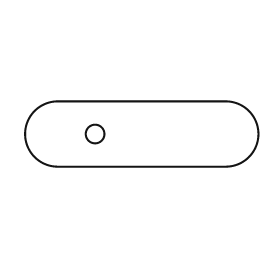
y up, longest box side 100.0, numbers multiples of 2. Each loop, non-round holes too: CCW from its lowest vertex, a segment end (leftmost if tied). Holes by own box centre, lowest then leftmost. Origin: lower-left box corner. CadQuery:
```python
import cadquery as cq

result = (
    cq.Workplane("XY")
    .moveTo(14.0, 0.0)
    .lineTo(86.0, 0.0)
    .threePointArc((100.0, 14.0), (86.0, 28.0))
    .lineTo(14.0, 28.0)
    .threePointArc((0.0, 14.0), (14.0, 0.0))
    .close()
    .moveTo(30.0, 14.0)
    .circle(4.0)
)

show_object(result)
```